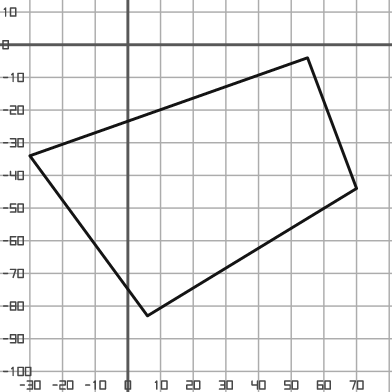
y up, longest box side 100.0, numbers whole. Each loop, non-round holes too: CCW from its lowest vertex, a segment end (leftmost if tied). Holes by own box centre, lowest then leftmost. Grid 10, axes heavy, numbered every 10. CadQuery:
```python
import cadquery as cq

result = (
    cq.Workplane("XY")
    .moveTo(6.0, -83.0)
    .lineTo(70.0, -44.0)
    .lineTo(55.0, -4.0)
    .lineTo(-30.0, -34.0)
    .close()
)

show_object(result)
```